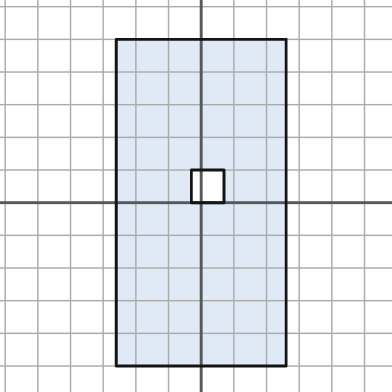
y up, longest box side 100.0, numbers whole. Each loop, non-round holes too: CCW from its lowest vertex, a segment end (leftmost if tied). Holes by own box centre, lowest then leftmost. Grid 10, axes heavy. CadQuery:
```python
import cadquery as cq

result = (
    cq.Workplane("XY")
    .moveTo(-26.0, -50.0)
    .lineTo(26.0, -50.0)
    .lineTo(26.0, 50.0)
    .lineTo(-26.0, 50.0)
    .close()
    .moveTo(-3.0, 0.0)
    .lineTo(7.0, 0.0)
    .lineTo(7.0, 10.0)
    .lineTo(-3.0, 10.0)
    .close()
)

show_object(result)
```